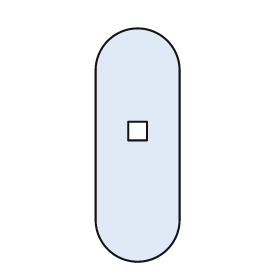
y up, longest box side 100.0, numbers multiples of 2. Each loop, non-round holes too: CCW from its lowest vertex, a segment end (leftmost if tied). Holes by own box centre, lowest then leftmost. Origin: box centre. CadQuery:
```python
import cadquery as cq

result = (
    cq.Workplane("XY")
    .moveTo(-18.0, -32.0)
    .threePointArc((0.0, -50.0), (18.0, -32.0))
    .lineTo(18.0, 32.0)
    .threePointArc((0.0, 50.0), (-18.0, 32.0))
    .close()
    .moveTo(-4.0, 2.0)
    .lineTo(4.0, 2.0)
    .lineTo(4.0, 10.0)
    .lineTo(-4.0, 10.0)
    .close()
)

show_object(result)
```